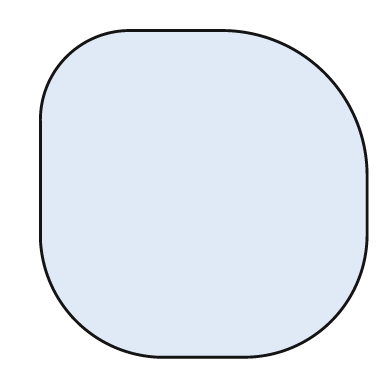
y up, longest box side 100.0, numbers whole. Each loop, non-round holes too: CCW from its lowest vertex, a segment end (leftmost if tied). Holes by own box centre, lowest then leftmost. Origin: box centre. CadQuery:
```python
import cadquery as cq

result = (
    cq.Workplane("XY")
    .moveTo(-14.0, -50.0)
    .lineTo(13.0, -50.0)
    .threePointArc((39.0, -39.0), (50.0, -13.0))
    .lineTo(50.0, 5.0)
    .threePointArc((37.0, 37.0), (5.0, 50.0))
    .lineTo(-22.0, 50.0)
    .threePointArc((-42.0, 42.0), (-50.0, 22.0))
    .lineTo(-50.0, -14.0)
    .threePointArc((-39.0, -39.0), (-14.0, -50.0))
    .close()
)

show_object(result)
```